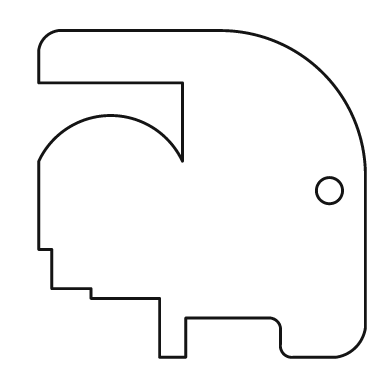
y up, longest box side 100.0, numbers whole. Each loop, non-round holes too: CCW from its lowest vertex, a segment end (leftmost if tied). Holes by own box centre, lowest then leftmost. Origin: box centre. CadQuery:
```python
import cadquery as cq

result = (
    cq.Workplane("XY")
    .moveTo(-13.0, -50.0)
    .lineTo(-5.0, -50.0)
    .lineTo(-5.0, -38.0)
    .lineTo(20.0, -38.0)
    .threePointArc((23.0, -39.0), (24.0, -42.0))
    .lineTo(24.0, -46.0)
    .threePointArc((25.0, -49.0), (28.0, -50.0))
    .lineTo(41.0, -50.0)
    .threePointArc((47.0, -47.0), (50.0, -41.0))
    .lineTo(50.0, 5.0)
    .threePointArc((37.0, 37.0), (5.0, 50.0))
    .lineTo(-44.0, 50.0)
    .threePointArc((-48.0, 48.0), (-50.0, 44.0))
    .lineTo(-50.0, 34.0)
    .lineTo(-6.0, 34.0)
    .lineTo(-6.0, 10.0)
    .threePointArc((-28.0, 24.0), (-50.0, 10.0))
    .lineTo(-50.0, -17.0)
    .lineTo(-46.0, -17.0)
    .lineTo(-46.0, -29.0)
    .lineTo(-34.0, -29.0)
    .lineTo(-34.0, -32.0)
    .lineTo(-13.0, -32.0)
    .close()
    .moveTo(39.0, 1.0)
    .circle(4.0)
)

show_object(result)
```